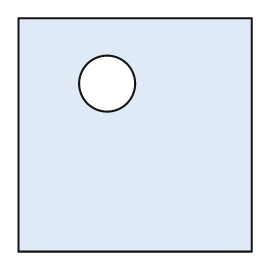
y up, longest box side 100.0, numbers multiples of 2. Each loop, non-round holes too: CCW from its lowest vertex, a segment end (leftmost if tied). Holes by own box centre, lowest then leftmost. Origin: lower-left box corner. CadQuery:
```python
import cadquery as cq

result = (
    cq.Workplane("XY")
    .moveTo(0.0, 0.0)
    .lineTo(100.0, 0.0)
    .lineTo(100.0, 100.0)
    .lineTo(0.0, 100.0)
    .close()
    .moveTo(38.0, 72.0)
    .circle(12.0)
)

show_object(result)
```